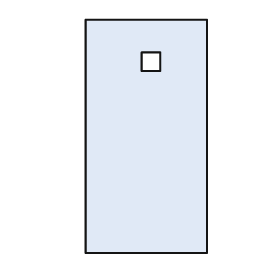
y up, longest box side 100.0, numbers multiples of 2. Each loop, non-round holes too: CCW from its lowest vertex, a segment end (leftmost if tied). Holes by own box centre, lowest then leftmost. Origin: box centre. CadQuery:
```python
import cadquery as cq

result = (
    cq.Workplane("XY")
    .moveTo(-26.0, -50.0)
    .lineTo(26.0, -50.0)
    .lineTo(26.0, 50.0)
    .lineTo(-26.0, 50.0)
    .close()
    .moveTo(-2.0, 28.0)
    .lineTo(6.0, 28.0)
    .lineTo(6.0, 36.0)
    .lineTo(-2.0, 36.0)
    .close()
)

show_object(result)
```